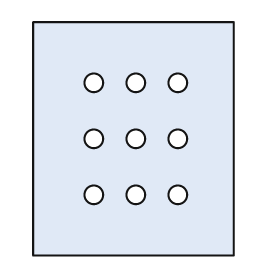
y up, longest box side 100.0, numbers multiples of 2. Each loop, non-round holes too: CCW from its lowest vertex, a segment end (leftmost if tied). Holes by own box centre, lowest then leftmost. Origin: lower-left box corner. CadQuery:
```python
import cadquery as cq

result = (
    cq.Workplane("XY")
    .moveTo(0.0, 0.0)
    .lineTo(86.0, 0.0)
    .lineTo(86.0, 100.0)
    .lineTo(0.0, 100.0)
    .close()
    .moveTo(26.0, 26.0)
    .circle(4.0)
    .moveTo(44.0, 26.0)
    .circle(4.0)
    .moveTo(62.0, 26.0)
    .circle(4.0)
    .moveTo(26.0, 50.0)
    .circle(4.0)
    .moveTo(44.0, 50.0)
    .circle(4.0)
    .moveTo(62.0, 50.0)
    .circle(4.0)
    .moveTo(26.0, 74.0)
    .circle(4.0)
    .moveTo(44.0, 74.0)
    .circle(4.0)
    .moveTo(62.0, 74.0)
    .circle(4.0)
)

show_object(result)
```